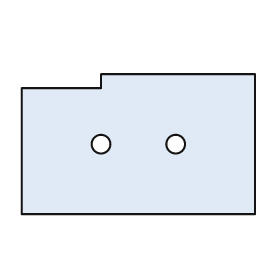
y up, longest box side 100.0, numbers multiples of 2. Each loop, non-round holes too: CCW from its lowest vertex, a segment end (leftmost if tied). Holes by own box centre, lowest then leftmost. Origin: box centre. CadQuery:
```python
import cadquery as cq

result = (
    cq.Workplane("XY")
    .moveTo(-50.0, -30.0)
    .lineTo(50.0, -30.0)
    .lineTo(50.0, 30.0)
    .lineTo(-16.0, 30.0)
    .lineTo(-16.0, 24.0)
    .lineTo(-50.0, 24.0)
    .close()
    .moveTo(-16.0, 0.0)
    .circle(4.0)
    .moveTo(16.0, 0.0)
    .circle(4.0)
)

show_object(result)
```